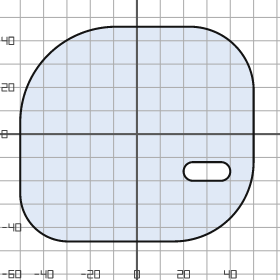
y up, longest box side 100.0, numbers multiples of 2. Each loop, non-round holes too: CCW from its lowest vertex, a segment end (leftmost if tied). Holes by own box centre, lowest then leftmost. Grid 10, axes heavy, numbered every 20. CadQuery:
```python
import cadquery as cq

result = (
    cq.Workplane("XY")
    .moveTo(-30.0, -46.0)
    .lineTo(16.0, -46.0)
    .threePointArc((40.0, -36.0), (50.0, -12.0))
    .lineTo(50.0, 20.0)
    .threePointArc((42.0, 38.0), (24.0, 46.0))
    .lineTo(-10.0, 46.0)
    .threePointArc((-38.0, 34.0), (-50.0, 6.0))
    .lineTo(-50.0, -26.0)
    .threePointArc((-44.0, -40.0), (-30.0, -46.0))
    .close()
    .moveTo(24.0, -20.0)
    .lineTo(36.0, -20.0)
    .threePointArc((40.0, -16.0), (36.0, -12.0))
    .lineTo(24.0, -12.0)
    .threePointArc((20.0, -16.0), (24.0, -20.0))
    .close()
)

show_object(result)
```